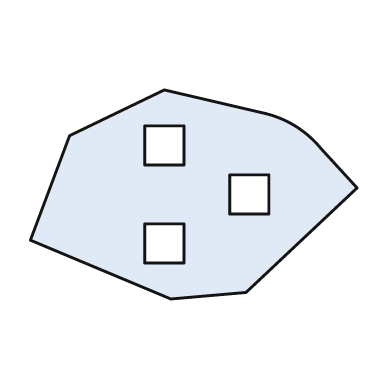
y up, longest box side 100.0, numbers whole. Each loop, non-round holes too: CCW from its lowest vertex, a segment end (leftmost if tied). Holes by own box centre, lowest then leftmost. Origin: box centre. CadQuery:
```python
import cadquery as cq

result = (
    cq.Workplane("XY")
    .moveTo(-7.0, -32.0)
    .lineTo(16.0, -30.0)
    .lineTo(50.0, 2.0)
    .lineTo(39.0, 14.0)
    .threePointArc((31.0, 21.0), (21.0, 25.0))
    .lineTo(-9.0, 32.0)
    .lineTo(-38.0, 18.0)
    .lineTo(-50.0, -14.0)
    .close()
    .moveTo(-15.0, -21.0)
    .lineTo(-3.0, -21.0)
    .lineTo(-3.0, -9.0)
    .lineTo(-15.0, -9.0)
    .close()
    .moveTo(11.0, -6.0)
    .lineTo(23.0, -6.0)
    .lineTo(23.0, 6.0)
    .lineTo(11.0, 6.0)
    .close()
    .moveTo(-15.0, 9.0)
    .lineTo(-3.0, 9.0)
    .lineTo(-3.0, 21.0)
    .lineTo(-15.0, 21.0)
    .close()
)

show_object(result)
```